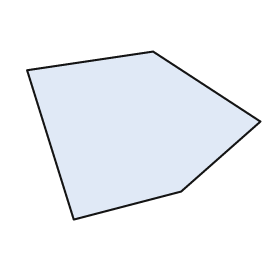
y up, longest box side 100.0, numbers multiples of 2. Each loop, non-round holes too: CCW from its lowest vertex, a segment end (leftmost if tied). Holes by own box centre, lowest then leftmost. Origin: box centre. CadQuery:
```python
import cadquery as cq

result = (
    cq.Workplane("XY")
    .moveTo(-30.0, -36.0)
    .lineTo(16.0, -24.0)
    .lineTo(50.0, 6.0)
    .lineTo(4.0, 36.0)
    .lineTo(-50.0, 28.0)
    .close()
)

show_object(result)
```